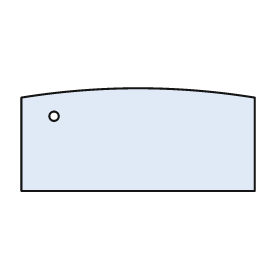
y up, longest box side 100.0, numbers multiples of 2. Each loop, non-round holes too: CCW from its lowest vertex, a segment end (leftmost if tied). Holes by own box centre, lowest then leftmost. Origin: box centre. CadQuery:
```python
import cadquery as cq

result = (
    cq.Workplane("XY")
    .moveTo(-50.0, -22.0)
    .lineTo(50.0, -22.0)
    .lineTo(50.0, 18.0)
    .threePointArc((0.0, 22.0), (-50.0, 18.0))
    .close()
    .moveTo(-36.0, 10.0)
    .circle(2.0)
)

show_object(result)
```